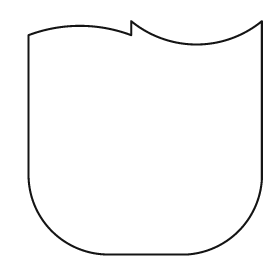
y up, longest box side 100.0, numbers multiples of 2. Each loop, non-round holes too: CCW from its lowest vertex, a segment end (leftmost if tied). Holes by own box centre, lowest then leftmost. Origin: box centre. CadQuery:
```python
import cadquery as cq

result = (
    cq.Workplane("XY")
    .moveTo(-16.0, -50.0)
    .lineTo(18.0, -50.0)
    .threePointArc((40.0, -40.0), (50.0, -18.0))
    .lineTo(50.0, 50.0)
    .threePointArc((22.0, 40.0), (-6.0, 50.0))
    .lineTo(-6.0, 44.0)
    .threePointArc((-28.0, 48.0), (-50.0, 44.0))
    .lineTo(-50.0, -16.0)
    .threePointArc((-40.0, -40.0), (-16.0, -50.0))
    .close()
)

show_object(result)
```